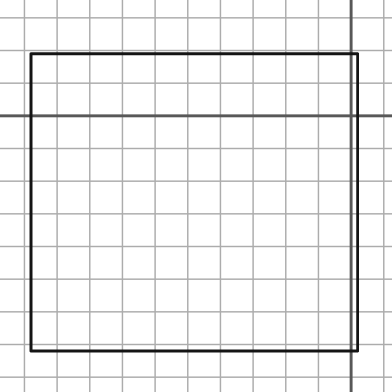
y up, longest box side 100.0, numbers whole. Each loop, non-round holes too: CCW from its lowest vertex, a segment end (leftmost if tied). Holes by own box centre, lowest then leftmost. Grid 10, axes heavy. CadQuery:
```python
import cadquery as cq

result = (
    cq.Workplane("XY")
    .moveTo(-98.0, -72.0)
    .lineTo(2.0, -72.0)
    .lineTo(2.0, 19.0)
    .lineTo(-98.0, 19.0)
    .close()
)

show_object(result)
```